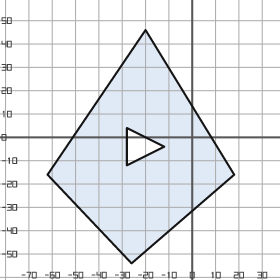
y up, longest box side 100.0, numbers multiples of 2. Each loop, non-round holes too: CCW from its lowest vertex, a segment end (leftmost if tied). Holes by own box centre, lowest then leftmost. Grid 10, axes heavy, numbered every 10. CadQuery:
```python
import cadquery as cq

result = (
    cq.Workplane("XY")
    .moveTo(-26.0, -54.0)
    .lineTo(18.0, -16.0)
    .lineTo(-20.0, 46.0)
    .lineTo(-62.0, -16.0)
    .close()
    .moveTo(-28.0, -12.0)
    .lineTo(-12.0, -4.0)
    .lineTo(-28.0, 4.0)
    .close()
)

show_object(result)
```